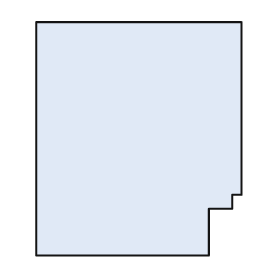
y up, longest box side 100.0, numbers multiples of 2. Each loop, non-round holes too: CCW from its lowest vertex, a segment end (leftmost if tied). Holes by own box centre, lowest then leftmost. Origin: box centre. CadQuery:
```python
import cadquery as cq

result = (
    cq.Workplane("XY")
    .moveTo(-44.0, -50.0)
    .lineTo(30.0, -50.0)
    .lineTo(30.0, -30.0)
    .lineTo(40.0, -30.0)
    .lineTo(40.0, -24.0)
    .lineTo(44.0, -24.0)
    .lineTo(44.0, 50.0)
    .lineTo(-44.0, 50.0)
    .close()
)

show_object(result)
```